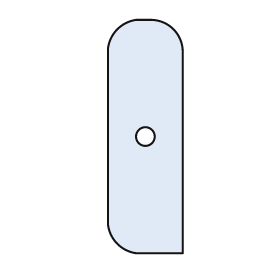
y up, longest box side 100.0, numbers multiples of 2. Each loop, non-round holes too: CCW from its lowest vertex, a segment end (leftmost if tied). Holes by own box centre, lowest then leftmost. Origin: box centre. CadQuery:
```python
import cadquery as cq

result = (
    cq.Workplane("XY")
    .moveTo(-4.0, -50.0)
    .lineTo(16.0, -50.0)
    .lineTo(16.0, 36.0)
    .threePointArc((12.0, 46.0), (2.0, 50.0))
    .lineTo(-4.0, 50.0)
    .threePointArc((-12.0, 46.0), (-16.0, 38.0))
    .lineTo(-16.0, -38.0)
    .threePointArc((-12.0, -46.0), (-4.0, -50.0))
    .close()
    .moveTo(0.0, 0.0)
    .circle(4.0)
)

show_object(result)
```